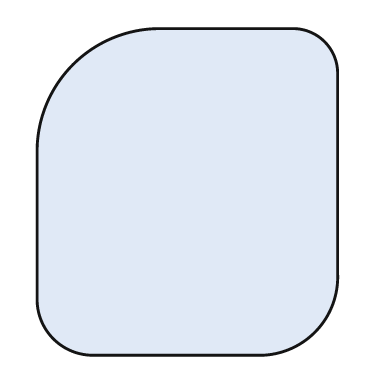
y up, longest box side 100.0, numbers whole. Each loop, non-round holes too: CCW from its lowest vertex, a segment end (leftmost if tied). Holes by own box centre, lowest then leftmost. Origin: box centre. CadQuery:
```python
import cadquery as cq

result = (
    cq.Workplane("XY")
    .moveTo(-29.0, -50.0)
    .lineTo(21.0, -50.0)
    .threePointArc((39.0, -43.0), (46.0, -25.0))
    .lineTo(46.0, 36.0)
    .threePointArc((42.0, 46.0), (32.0, 50.0))
    .lineTo(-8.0, 50.0)
    .threePointArc((-35.0, 39.0), (-46.0, 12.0))
    .lineTo(-46.0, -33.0)
    .threePointArc((-41.0, -45.0), (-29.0, -50.0))
    .close()
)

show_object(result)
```